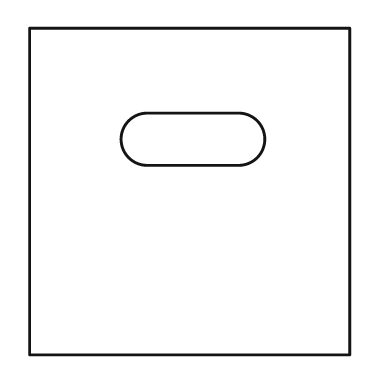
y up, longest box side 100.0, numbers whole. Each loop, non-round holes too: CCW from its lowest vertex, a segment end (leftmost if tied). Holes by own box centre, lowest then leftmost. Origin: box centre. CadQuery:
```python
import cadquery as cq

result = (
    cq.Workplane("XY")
    .moveTo(-49.0, -50.0)
    .lineTo(49.0, -50.0)
    .lineTo(49.0, 50.0)
    .lineTo(-49.0, 50.0)
    .close()
    .moveTo(-13.0, 8.0)
    .lineTo(15.0, 8.0)
    .threePointArc((23.0, 16.0), (15.0, 24.0))
    .lineTo(-13.0, 24.0)
    .threePointArc((-21.0, 16.0), (-13.0, 8.0))
    .close()
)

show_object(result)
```